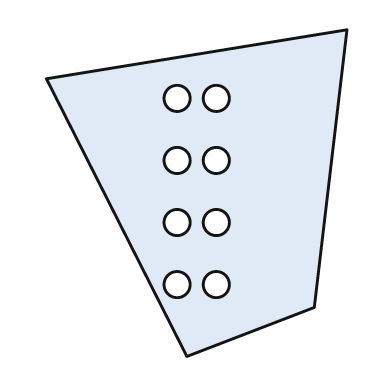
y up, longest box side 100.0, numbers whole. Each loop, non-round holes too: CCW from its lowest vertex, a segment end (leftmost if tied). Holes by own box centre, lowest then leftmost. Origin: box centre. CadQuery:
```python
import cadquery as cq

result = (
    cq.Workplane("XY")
    .moveTo(-3.0, -50.0)
    .lineTo(36.0, -35.0)
    .lineTo(46.0, 50.0)
    .lineTo(-46.0, 35.0)
    .close()
    .moveTo(-6.0, -28.0)
    .circle(4.0)
    .moveTo(6.0, -28.0)
    .circle(4.0)
    .moveTo(-6.0, -9.0)
    .circle(4.0)
    .moveTo(6.0, -9.0)
    .circle(4.0)
    .moveTo(-6.0, 10.0)
    .circle(4.0)
    .moveTo(6.0, 10.0)
    .circle(4.0)
    .moveTo(-6.0, 29.0)
    .circle(4.0)
    .moveTo(6.0, 29.0)
    .circle(4.0)
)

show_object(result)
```